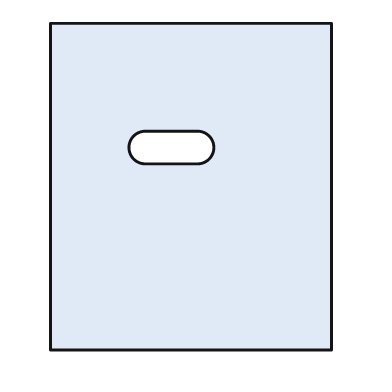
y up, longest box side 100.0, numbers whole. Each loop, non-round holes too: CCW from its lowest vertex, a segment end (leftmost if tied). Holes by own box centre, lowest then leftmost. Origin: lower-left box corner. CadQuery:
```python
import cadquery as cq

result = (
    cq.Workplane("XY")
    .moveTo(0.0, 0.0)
    .lineTo(86.0, 0.0)
    .lineTo(86.0, 100.0)
    .lineTo(0.0, 100.0)
    .close()
    .moveTo(29.0, 57.0)
    .lineTo(45.0, 57.0)
    .threePointArc((50.0, 62.0), (45.0, 67.0))
    .lineTo(29.0, 67.0)
    .threePointArc((24.0, 62.0), (29.0, 57.0))
    .close()
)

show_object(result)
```